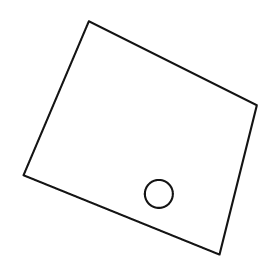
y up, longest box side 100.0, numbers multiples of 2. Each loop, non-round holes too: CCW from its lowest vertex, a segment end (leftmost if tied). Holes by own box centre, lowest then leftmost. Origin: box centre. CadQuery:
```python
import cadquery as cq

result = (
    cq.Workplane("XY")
    .moveTo(34.0, -50.0)
    .lineTo(50.0, 14.0)
    .lineTo(-22.0, 50.0)
    .lineTo(-50.0, -16.0)
    .close()
    .moveTo(8.0, -24.0)
    .circle(6.0)
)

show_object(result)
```